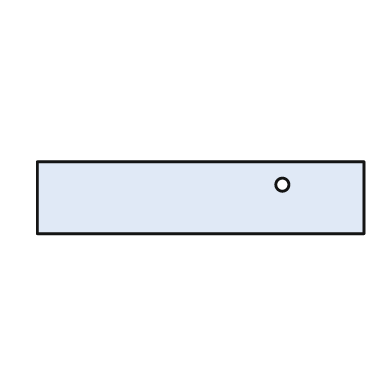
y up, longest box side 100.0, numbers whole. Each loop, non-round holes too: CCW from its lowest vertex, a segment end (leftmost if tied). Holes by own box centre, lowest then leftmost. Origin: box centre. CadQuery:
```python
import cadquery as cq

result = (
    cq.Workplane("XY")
    .moveTo(-50.0, -11.0)
    .lineTo(50.0, -11.0)
    .lineTo(50.0, 11.0)
    .lineTo(-50.0, 11.0)
    .close()
    .moveTo(25.0, 4.0)
    .circle(2.0)
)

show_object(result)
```